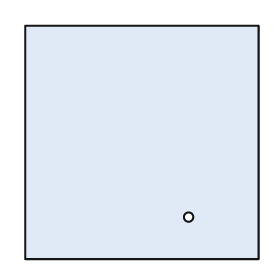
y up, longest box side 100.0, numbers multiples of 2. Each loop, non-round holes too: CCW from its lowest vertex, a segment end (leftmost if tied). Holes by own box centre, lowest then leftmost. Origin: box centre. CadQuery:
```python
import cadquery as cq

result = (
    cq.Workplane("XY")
    .moveTo(-50.0, -50.0)
    .lineTo(50.0, -50.0)
    .lineTo(50.0, 50.0)
    .lineTo(-50.0, 50.0)
    .close()
    .moveTo(20.0, -32.0)
    .circle(2.0)
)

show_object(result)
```